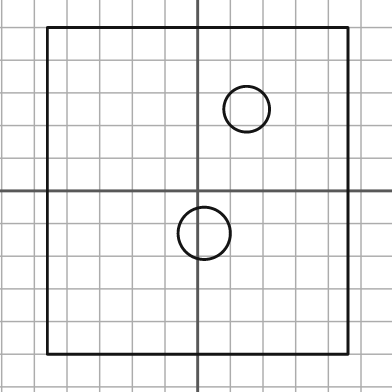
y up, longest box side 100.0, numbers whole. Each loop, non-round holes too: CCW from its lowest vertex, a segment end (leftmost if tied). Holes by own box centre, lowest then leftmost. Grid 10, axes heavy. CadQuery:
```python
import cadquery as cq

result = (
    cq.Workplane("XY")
    .moveTo(-46.0, -50.0)
    .lineTo(46.0, -50.0)
    .lineTo(46.0, 50.0)
    .lineTo(-46.0, 50.0)
    .close()
    .moveTo(2.0, -13.0)
    .circle(8.0)
    .moveTo(15.0, 25.0)
    .circle(7.0)
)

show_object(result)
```